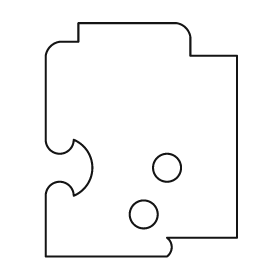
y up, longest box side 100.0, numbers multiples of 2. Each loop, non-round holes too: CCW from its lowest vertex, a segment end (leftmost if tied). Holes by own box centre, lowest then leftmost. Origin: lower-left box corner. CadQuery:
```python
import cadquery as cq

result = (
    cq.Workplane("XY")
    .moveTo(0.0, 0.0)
    .lineTo(52.0, 0.0)
    .threePointArc((54.0, 4.0), (52.0, 8.0))
    .lineTo(82.0, 8.0)
    .lineTo(82.0, 86.0)
    .lineTo(62.0, 86.0)
    .lineTo(62.0, 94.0)
    .threePointArc((60.0, 98.0), (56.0, 100.0))
    .lineTo(14.0, 100.0)
    .lineTo(14.0, 92.0)
    .lineTo(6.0, 92.0)
    .threePointArc((2.0, 90.0), (0.0, 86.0))
    .lineTo(0.0, 50.0)
    .threePointArc((6.0, 44.0), (12.0, 50.0))
    .threePointArc((20.0, 38.0), (12.0, 26.0))
    .threePointArc((6.0, 32.0), (0.0, 26.0))
    .close()
    .moveTo(42.0, 18.0)
    .circle(6.0)
    .moveTo(52.0, 38.0)
    .circle(6.0)
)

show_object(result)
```